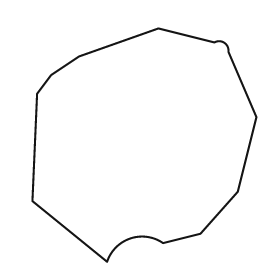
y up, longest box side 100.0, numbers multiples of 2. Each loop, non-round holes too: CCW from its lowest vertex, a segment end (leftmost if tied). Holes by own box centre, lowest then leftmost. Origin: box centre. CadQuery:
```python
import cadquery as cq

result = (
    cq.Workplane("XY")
    .moveTo(-16.0, -50.0)
    .threePointArc((-6.0, -40.0), (8.0, -42.0))
    .lineTo(24.0, -38.0)
    .lineTo(40.0, -20.0)
    .lineTo(48.0, 12.0)
    .lineTo(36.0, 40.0)
    .threePointArc((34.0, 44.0), (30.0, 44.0))
    .lineTo(6.0, 50.0)
    .lineTo(-28.0, 38.0)
    .lineTo(-40.0, 30.0)
    .lineTo(-46.0, 22.0)
    .lineTo(-48.0, -24.0)
    .close()
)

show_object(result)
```